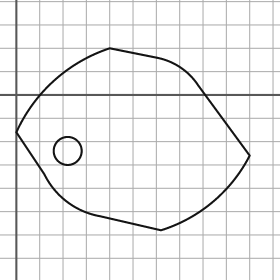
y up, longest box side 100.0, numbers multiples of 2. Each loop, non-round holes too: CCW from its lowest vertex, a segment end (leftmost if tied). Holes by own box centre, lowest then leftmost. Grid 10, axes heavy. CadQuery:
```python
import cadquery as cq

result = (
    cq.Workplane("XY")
    .moveTo(62.0, -58.0)
    .threePointArc((84.0, -46.0), (100.0, -26.0))
    .lineTo(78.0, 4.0)
    .threePointArc((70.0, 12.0), (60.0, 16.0))
    .lineTo(40.0, 20.0)
    .threePointArc((16.0, 6.0), (0.0, -16.0))
    .lineTo(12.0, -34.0)
    .threePointArc((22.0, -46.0), (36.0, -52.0))
    .close()
    .moveTo(22.0, -24.0)
    .circle(6.0)
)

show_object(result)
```